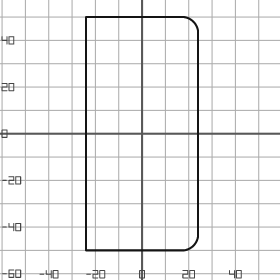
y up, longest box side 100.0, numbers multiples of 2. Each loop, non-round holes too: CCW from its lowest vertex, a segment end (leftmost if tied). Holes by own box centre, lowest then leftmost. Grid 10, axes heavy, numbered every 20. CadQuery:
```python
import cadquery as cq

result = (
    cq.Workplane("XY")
    .moveTo(-24.0, -50.0)
    .lineTo(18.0, -50.0)
    .threePointArc((22.0, -48.0), (24.0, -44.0))
    .lineTo(24.0, 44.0)
    .threePointArc((22.0, 48.0), (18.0, 50.0))
    .lineTo(-24.0, 50.0)
    .close()
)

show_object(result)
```